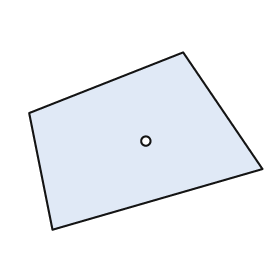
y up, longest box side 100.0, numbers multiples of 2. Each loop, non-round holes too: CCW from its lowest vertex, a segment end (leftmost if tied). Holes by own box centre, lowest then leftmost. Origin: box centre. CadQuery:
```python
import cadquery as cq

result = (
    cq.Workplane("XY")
    .moveTo(-40.0, -38.0)
    .lineTo(50.0, -12.0)
    .lineTo(16.0, 38.0)
    .lineTo(-50.0, 12.0)
    .close()
    .moveTo(0.0, 0.0)
    .circle(2.0)
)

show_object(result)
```